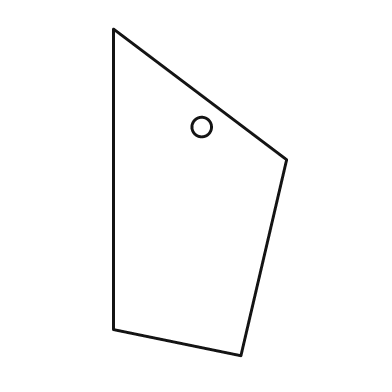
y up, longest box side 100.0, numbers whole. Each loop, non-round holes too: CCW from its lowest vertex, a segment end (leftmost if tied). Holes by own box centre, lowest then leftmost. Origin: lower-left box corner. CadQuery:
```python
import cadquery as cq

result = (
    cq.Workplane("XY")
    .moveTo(39.0, 0.0)
    .lineTo(53.0, 60.0)
    .lineTo(0.0, 100.0)
    .lineTo(0.0, 8.0)
    .close()
    .moveTo(27.0, 70.0)
    .circle(3.0)
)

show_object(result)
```